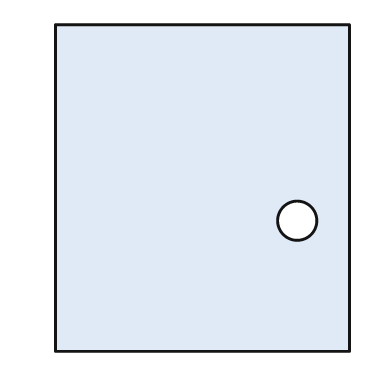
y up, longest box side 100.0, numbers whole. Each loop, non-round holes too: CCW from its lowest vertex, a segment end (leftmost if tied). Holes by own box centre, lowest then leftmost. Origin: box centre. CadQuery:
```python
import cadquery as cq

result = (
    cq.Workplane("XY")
    .moveTo(-45.0, -50.0)
    .lineTo(45.0, -50.0)
    .lineTo(45.0, 50.0)
    .lineTo(-45.0, 50.0)
    .close()
    .moveTo(29.0, -10.0)
    .circle(6.0)
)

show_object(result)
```